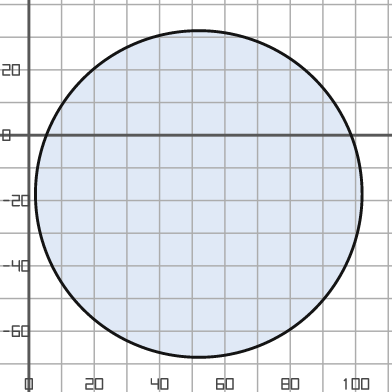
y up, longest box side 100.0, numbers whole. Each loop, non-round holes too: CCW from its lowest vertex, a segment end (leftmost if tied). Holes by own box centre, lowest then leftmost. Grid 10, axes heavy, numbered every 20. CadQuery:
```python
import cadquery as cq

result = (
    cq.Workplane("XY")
    .moveTo(52.0, -18.0)
    .circle(50.0)
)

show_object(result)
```